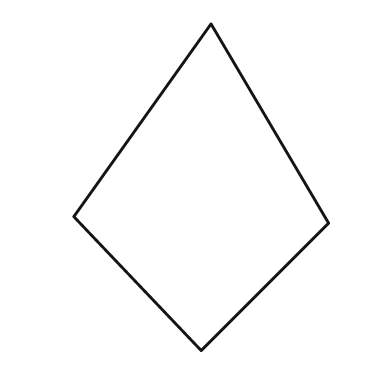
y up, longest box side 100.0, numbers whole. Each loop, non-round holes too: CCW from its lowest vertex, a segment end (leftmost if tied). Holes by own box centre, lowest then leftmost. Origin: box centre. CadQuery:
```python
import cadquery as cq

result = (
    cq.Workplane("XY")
    .moveTo(0.0, -50.0)
    .lineTo(39.0, -11.0)
    .lineTo(3.0, 50.0)
    .lineTo(-39.0, -9.0)
    .close()
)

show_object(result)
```